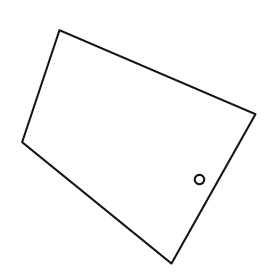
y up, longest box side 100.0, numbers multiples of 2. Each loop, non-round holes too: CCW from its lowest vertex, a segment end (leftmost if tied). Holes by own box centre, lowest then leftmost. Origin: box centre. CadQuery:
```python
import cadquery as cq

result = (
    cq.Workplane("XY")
    .moveTo(14.0, -50.0)
    .lineTo(50.0, 14.0)
    .lineTo(-34.0, 50.0)
    .lineTo(-50.0, 2.0)
    .close()
    .moveTo(26.0, -14.0)
    .circle(2.0)
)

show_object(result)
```